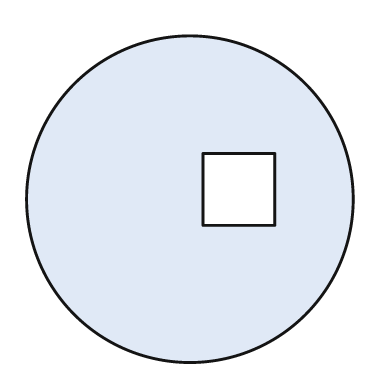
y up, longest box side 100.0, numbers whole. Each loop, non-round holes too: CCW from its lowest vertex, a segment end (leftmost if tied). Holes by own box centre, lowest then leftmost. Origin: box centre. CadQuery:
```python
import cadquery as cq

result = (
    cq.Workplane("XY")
    .moveTo(0.0, 0.0)
    .circle(50.0)
    .moveTo(4.0, -8.0)
    .lineTo(26.0, -8.0)
    .lineTo(26.0, 14.0)
    .lineTo(4.0, 14.0)
    .close()
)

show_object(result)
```